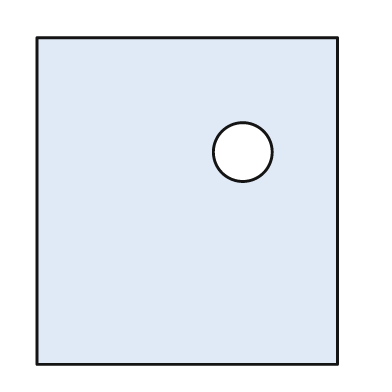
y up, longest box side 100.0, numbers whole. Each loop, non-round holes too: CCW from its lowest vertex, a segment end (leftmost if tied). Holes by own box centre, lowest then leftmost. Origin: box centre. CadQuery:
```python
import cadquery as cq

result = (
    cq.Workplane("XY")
    .moveTo(-46.0, -50.0)
    .lineTo(46.0, -50.0)
    .lineTo(46.0, 50.0)
    .lineTo(-46.0, 50.0)
    .close()
    .moveTo(17.0, 15.0)
    .circle(9.0)
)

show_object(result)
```